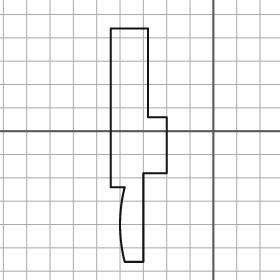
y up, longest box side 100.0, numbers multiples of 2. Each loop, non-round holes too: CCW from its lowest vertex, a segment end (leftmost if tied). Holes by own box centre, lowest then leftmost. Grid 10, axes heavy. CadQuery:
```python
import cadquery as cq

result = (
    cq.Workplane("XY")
    .moveTo(-38.0, -56.0)
    .lineTo(-30.0, -56.0)
    .lineTo(-30.0, -18.0)
    .lineTo(-20.0, -18.0)
    .lineTo(-20.0, 6.0)
    .lineTo(-28.0, 6.0)
    .lineTo(-28.0, 44.0)
    .lineTo(-44.0, 44.0)
    .lineTo(-44.0, -24.0)
    .lineTo(-38.0, -24.0)
    .threePointArc((-40.0, -40.0), (-38.0, -56.0))
    .close()
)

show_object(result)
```